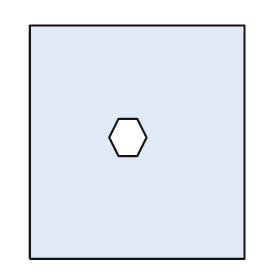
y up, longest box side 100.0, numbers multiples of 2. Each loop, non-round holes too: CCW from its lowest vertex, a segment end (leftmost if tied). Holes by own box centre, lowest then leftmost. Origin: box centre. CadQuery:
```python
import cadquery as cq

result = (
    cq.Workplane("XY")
    .moveTo(-46.0, -50.0)
    .lineTo(46.0, -50.0)
    .lineTo(46.0, 50.0)
    .lineTo(-46.0, 50.0)
    .close()
    .moveTo(-8.0, -6.0)
    .lineTo(0.0, -6.0)
    .lineTo(4.0, 2.0)
    .lineTo(0.0, 10.0)
    .lineTo(-8.0, 10.0)
    .lineTo(-12.0, 2.0)
    .close()
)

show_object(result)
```